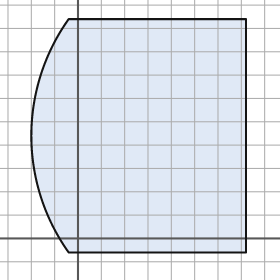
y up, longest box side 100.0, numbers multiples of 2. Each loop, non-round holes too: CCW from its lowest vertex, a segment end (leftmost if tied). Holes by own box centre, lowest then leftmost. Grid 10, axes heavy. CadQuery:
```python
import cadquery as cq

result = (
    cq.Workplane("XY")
    .moveTo(-4.0, -6.0)
    .lineTo(72.0, -6.0)
    .lineTo(72.0, 94.0)
    .lineTo(-4.0, 94.0)
    .threePointArc((-20.0, 44.0), (-4.0, -6.0))
    .close()
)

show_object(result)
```